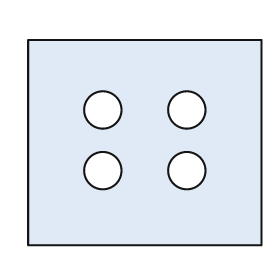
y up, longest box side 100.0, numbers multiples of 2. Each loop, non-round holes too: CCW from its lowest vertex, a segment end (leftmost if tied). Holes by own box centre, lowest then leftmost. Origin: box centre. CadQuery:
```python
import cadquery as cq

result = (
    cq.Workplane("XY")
    .moveTo(-50.0, -44.0)
    .lineTo(50.0, -44.0)
    .lineTo(50.0, 44.0)
    .lineTo(-50.0, 44.0)
    .close()
    .moveTo(-18.0, -12.0)
    .circle(8.0)
    .moveTo(18.0, -12.0)
    .circle(8.0)
    .moveTo(-18.0, 14.0)
    .circle(8.0)
    .moveTo(18.0, 14.0)
    .circle(8.0)
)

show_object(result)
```